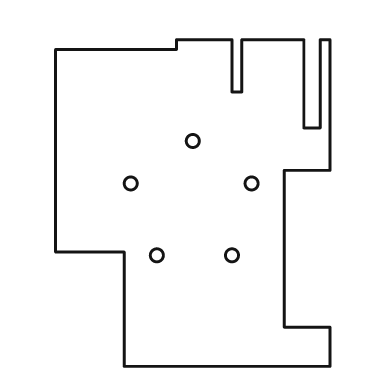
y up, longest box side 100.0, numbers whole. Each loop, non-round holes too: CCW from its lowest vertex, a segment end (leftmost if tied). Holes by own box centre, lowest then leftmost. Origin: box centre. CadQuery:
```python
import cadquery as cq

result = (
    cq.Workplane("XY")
    .moveTo(-21.0, -50.0)
    .lineTo(42.0, -50.0)
    .lineTo(42.0, -38.0)
    .lineTo(28.0, -38.0)
    .lineTo(28.0, 10.0)
    .lineTo(42.0, 10.0)
    .lineTo(42.0, 50.0)
    .lineTo(39.0, 50.0)
    .lineTo(39.0, 23.0)
    .lineTo(34.0, 23.0)
    .lineTo(34.0, 50.0)
    .lineTo(15.0, 50.0)
    .lineTo(15.0, 34.0)
    .lineTo(12.0, 34.0)
    .lineTo(12.0, 50.0)
    .lineTo(-5.0, 50.0)
    .lineTo(-5.0, 47.0)
    .lineTo(-42.0, 47.0)
    .lineTo(-42.0, -15.0)
    .lineTo(-21.0, -15.0)
    .close()
    .moveTo(-11.0, -16.0)
    .circle(2.0)
    .moveTo(12.0, -16.0)
    .circle(2.0)
    .moveTo(-19.0, 6.0)
    .circle(2.0)
    .moveTo(18.0, 6.0)
    .circle(2.0)
    .moveTo(0.0, 19.0)
    .circle(2.0)
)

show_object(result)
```